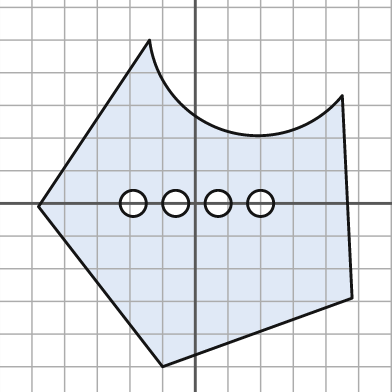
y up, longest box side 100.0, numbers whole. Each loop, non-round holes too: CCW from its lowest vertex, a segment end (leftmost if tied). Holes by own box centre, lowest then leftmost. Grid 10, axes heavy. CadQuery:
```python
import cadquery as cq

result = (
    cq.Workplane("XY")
    .moveTo(-10.0, -50.0)
    .lineTo(48.0, -29.0)
    .lineTo(45.0, 33.0)
    .threePointArc((10.0, 22.0), (-14.0, 50.0))
    .lineTo(-48.0, -1.0)
    .close()
    .moveTo(-19.0, 0.0)
    .circle(4.0)
    .moveTo(-6.0, 0.0)
    .circle(4.0)
    .moveTo(7.0, 0.0)
    .circle(4.0)
    .moveTo(20.0, 0.0)
    .circle(4.0)
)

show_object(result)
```